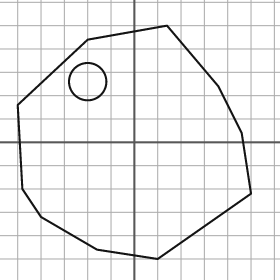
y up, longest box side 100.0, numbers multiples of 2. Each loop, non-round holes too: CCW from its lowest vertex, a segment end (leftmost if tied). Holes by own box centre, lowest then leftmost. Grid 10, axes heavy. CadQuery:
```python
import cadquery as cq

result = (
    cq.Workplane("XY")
    .moveTo(10.0, -50.0)
    .lineTo(50.0, -22.0)
    .lineTo(46.0, 4.0)
    .lineTo(36.0, 24.0)
    .lineTo(14.0, 50.0)
    .lineTo(-20.0, 44.0)
    .lineTo(-50.0, 16.0)
    .lineTo(-48.0, -20.0)
    .lineTo(-40.0, -32.0)
    .lineTo(-16.0, -46.0)
    .close()
    .moveTo(-20.0, 26.0)
    .circle(8.0)
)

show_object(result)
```